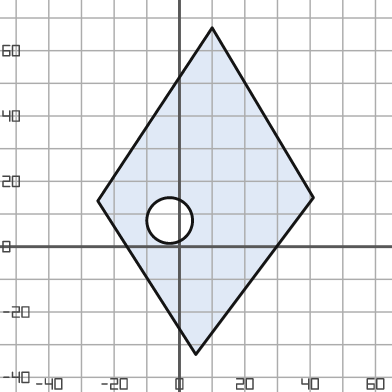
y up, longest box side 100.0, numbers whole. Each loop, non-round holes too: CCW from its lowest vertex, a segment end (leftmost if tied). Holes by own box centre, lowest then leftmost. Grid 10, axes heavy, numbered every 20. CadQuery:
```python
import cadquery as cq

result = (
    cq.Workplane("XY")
    .moveTo(5.0, -33.0)
    .lineTo(41.0, 15.0)
    .lineTo(10.0, 67.0)
    .lineTo(-25.0, 14.0)
    .close()
    .moveTo(-3.0, 8.0)
    .circle(7.0)
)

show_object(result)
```